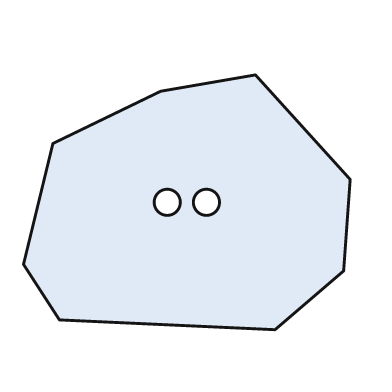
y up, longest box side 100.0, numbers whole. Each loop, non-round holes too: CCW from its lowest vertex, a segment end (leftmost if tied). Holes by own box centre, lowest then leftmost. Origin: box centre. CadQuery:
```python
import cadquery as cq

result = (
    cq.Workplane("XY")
    .moveTo(27.0, -39.0)
    .lineTo(48.0, -21.0)
    .lineTo(50.0, 7.0)
    .lineTo(21.0, 39.0)
    .lineTo(-8.0, 34.0)
    .lineTo(-41.0, 18.0)
    .lineTo(-50.0, -19.0)
    .lineTo(-39.0, -36.0)
    .close()
    .moveTo(-6.0, 0.0)
    .circle(4.0)
    .moveTo(6.0, 0.0)
    .circle(4.0)
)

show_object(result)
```